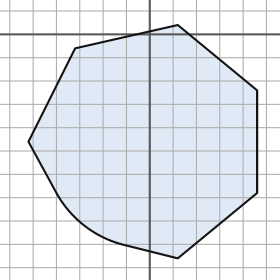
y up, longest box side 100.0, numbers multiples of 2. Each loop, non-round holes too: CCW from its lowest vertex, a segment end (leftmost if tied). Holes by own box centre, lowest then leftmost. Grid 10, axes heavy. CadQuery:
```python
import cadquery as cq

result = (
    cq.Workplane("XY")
    .moveTo(12.0, -96.0)
    .lineTo(46.0, -68.0)
    .lineTo(46.0, -24.0)
    .lineTo(12.0, 4.0)
    .lineTo(-32.0, -6.0)
    .lineTo(-52.0, -46.0)
    .lineTo(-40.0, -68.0)
    .threePointArc((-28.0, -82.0), (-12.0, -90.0))
    .close()
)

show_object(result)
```